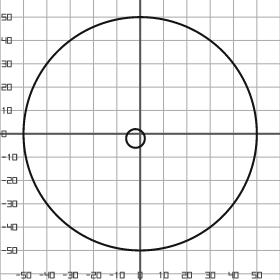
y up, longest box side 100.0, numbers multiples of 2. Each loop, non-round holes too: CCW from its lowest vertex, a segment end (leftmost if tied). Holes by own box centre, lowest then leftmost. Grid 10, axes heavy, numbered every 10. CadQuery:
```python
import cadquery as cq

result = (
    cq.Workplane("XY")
    .moveTo(0.0, 0.0)
    .circle(50.0)
    .moveTo(-2.0, -2.0)
    .circle(4.0)
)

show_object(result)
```